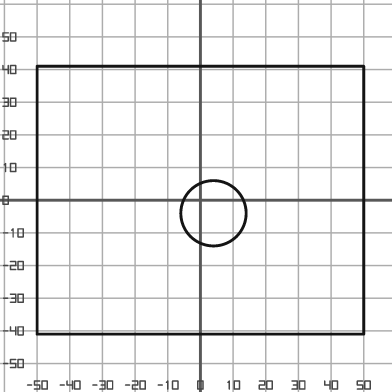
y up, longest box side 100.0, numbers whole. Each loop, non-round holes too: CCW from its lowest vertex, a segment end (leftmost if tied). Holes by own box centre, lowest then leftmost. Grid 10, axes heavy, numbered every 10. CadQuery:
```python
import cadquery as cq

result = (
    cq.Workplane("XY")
    .moveTo(-50.0, -41.0)
    .lineTo(50.0, -41.0)
    .lineTo(50.0, 41.0)
    .lineTo(-50.0, 41.0)
    .close()
    .moveTo(4.0, -4.0)
    .circle(10.0)
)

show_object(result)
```